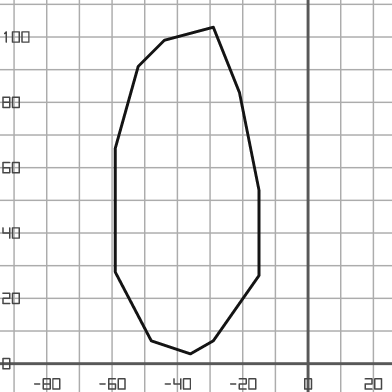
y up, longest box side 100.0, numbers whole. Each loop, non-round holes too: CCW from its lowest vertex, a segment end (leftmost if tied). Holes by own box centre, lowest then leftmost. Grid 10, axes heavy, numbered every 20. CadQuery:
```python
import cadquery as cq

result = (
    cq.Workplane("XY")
    .moveTo(-36.0, 3.0)
    .lineTo(-29.0, 7.0)
    .lineTo(-15.0, 27.0)
    .lineTo(-15.0, 53.0)
    .lineTo(-21.0, 83.0)
    .lineTo(-29.0, 103.0)
    .lineTo(-44.0, 99.0)
    .lineTo(-52.0, 91.0)
    .lineTo(-59.0, 66.0)
    .lineTo(-59.0, 28.0)
    .lineTo(-48.0, 7.0)
    .close()
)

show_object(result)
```